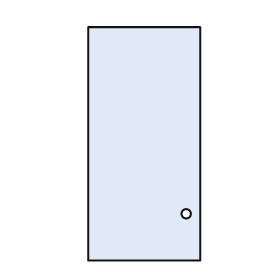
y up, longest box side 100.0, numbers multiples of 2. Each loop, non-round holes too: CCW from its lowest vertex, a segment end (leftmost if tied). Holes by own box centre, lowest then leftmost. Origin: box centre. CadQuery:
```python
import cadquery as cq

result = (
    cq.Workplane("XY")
    .moveTo(-24.0, -50.0)
    .lineTo(24.0, -50.0)
    .lineTo(24.0, 50.0)
    .lineTo(-24.0, 50.0)
    .close()
    .moveTo(18.0, -30.0)
    .circle(2.0)
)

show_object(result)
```